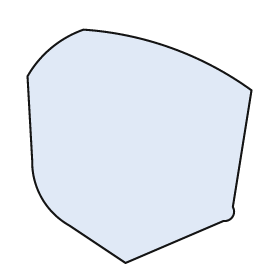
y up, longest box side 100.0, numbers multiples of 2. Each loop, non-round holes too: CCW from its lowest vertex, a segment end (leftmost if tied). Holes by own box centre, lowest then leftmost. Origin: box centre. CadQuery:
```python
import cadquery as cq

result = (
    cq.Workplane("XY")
    .moveTo(-6.0, -50.0)
    .lineTo(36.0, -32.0)
    .threePointArc((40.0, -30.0), (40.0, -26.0))
    .lineTo(48.0, 24.0)
    .threePointArc((14.0, 42.0), (-24.0, 50.0))
    .threePointArc((-38.0, 42.0), (-48.0, 30.0))
    .lineTo(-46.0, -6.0)
    .threePointArc((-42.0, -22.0), (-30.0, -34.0))
    .close()
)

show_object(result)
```